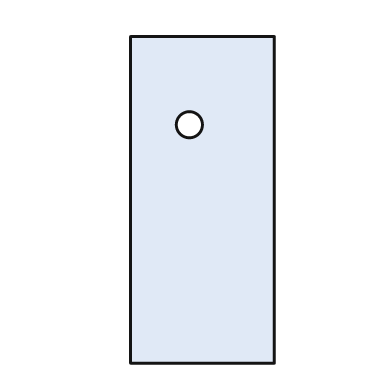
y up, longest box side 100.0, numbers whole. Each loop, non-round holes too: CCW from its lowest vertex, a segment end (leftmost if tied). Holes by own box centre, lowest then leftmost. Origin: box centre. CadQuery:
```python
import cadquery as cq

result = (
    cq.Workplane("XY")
    .moveTo(-22.0, -50.0)
    .lineTo(22.0, -50.0)
    .lineTo(22.0, 50.0)
    .lineTo(-22.0, 50.0)
    .close()
    .moveTo(-4.0, 23.0)
    .circle(4.0)
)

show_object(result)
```